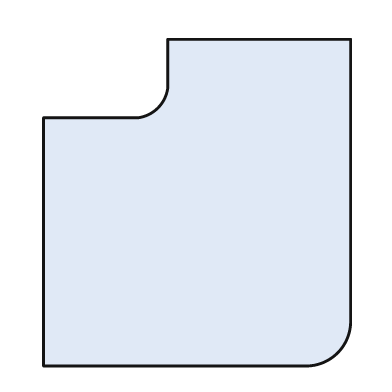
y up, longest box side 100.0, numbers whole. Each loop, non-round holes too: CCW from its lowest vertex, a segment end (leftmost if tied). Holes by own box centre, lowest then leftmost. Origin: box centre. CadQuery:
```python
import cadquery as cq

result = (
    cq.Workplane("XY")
    .moveTo(-47.0, -50.0)
    .lineTo(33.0, -50.0)
    .threePointArc((43.0, -46.0), (47.0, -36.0))
    .lineTo(47.0, 50.0)
    .lineTo(-9.0, 50.0)
    .lineTo(-9.0, 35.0)
    .threePointArc((-12.0, 29.0), (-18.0, 26.0))
    .lineTo(-47.0, 26.0)
    .close()
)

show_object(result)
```